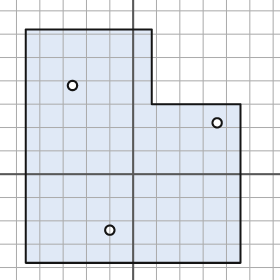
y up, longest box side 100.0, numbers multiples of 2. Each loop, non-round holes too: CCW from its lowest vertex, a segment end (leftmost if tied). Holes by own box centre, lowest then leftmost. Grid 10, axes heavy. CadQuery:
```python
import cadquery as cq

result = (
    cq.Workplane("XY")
    .moveTo(-46.0, -38.0)
    .lineTo(46.0, -38.0)
    .lineTo(46.0, 30.0)
    .lineTo(8.0, 30.0)
    .lineTo(8.0, 62.0)
    .lineTo(-46.0, 62.0)
    .close()
    .moveTo(-10.0, -24.0)
    .circle(2.0)
    .moveTo(36.0, 22.0)
    .circle(2.0)
    .moveTo(-26.0, 38.0)
    .circle(2.0)
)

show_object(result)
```